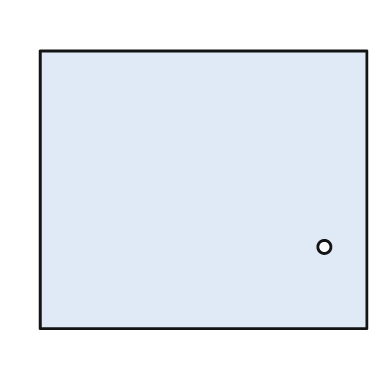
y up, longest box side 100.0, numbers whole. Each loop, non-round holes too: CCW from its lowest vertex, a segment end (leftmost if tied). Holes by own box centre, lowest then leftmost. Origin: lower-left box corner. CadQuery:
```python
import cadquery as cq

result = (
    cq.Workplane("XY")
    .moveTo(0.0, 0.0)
    .lineTo(100.0, 0.0)
    .lineTo(100.0, 85.0)
    .lineTo(0.0, 85.0)
    .close()
    .moveTo(87.0, 25.0)
    .circle(2.0)
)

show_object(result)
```